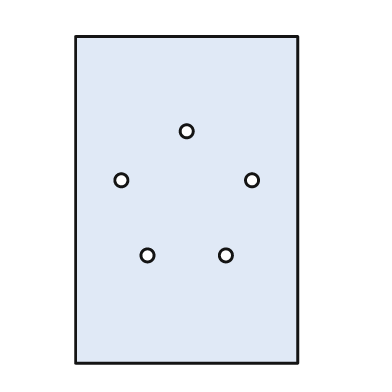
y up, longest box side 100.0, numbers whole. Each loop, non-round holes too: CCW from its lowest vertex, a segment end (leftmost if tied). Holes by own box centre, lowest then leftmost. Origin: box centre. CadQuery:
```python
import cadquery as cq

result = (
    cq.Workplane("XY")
    .moveTo(-34.0, -50.0)
    .lineTo(34.0, -50.0)
    .lineTo(34.0, 50.0)
    .lineTo(-34.0, 50.0)
    .close()
    .moveTo(-12.0, -17.0)
    .circle(2.0)
    .moveTo(12.0, -17.0)
    .circle(2.0)
    .moveTo(-20.0, 6.0)
    .circle(2.0)
    .moveTo(20.0, 6.0)
    .circle(2.0)
    .moveTo(0.0, 21.0)
    .circle(2.0)
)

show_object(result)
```